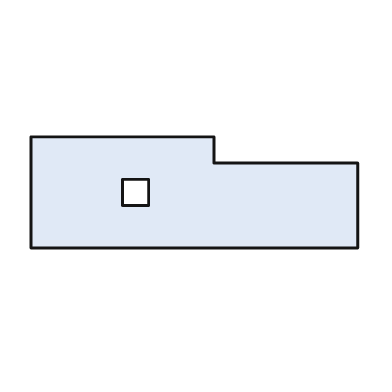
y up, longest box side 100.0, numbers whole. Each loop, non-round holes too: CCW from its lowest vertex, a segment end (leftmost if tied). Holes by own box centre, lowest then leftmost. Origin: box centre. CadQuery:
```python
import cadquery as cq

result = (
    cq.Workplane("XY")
    .moveTo(-50.0, -17.0)
    .lineTo(50.0, -17.0)
    .lineTo(50.0, 9.0)
    .lineTo(6.0, 9.0)
    .lineTo(6.0, 17.0)
    .lineTo(-50.0, 17.0)
    .close()
    .moveTo(-22.0, -4.0)
    .lineTo(-14.0, -4.0)
    .lineTo(-14.0, 4.0)
    .lineTo(-22.0, 4.0)
    .close()
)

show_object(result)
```